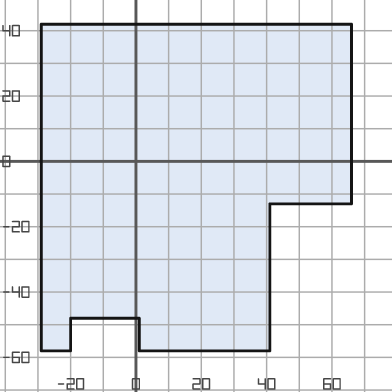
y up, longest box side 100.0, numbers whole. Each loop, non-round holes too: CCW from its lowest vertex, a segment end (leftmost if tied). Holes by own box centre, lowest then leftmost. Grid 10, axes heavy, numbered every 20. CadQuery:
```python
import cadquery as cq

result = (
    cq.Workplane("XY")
    .moveTo(-29.0, -58.0)
    .lineTo(-20.0, -58.0)
    .lineTo(-20.0, -48.0)
    .lineTo(1.0, -48.0)
    .lineTo(1.0, -58.0)
    .lineTo(41.0, -58.0)
    .lineTo(41.0, -13.0)
    .lineTo(66.0, -13.0)
    .lineTo(66.0, 42.0)
    .lineTo(-29.0, 42.0)
    .close()
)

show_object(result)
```